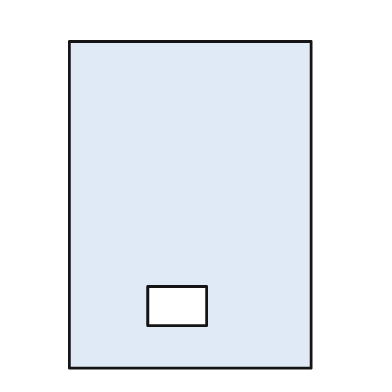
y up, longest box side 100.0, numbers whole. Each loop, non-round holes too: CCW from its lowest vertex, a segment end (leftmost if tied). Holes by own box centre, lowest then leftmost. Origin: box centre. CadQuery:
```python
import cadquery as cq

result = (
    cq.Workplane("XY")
    .moveTo(-37.0, -50.0)
    .lineTo(37.0, -50.0)
    .lineTo(37.0, 50.0)
    .lineTo(-37.0, 50.0)
    .close()
    .moveTo(-13.0, -37.0)
    .lineTo(5.0, -37.0)
    .lineTo(5.0, -25.0)
    .lineTo(-13.0, -25.0)
    .close()
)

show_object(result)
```